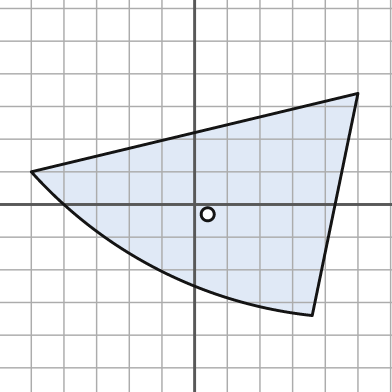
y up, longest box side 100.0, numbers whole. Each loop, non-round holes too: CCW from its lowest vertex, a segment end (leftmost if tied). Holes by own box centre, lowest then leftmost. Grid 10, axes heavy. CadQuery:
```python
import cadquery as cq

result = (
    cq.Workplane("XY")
    .moveTo(36.0, -34.0)
    .lineTo(50.0, 34.0)
    .lineTo(-50.0, 10.0)
    .threePointArc((-11.0, -20.0), (36.0, -34.0))
    .close()
    .moveTo(4.0, -3.0)
    .circle(2.0)
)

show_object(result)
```